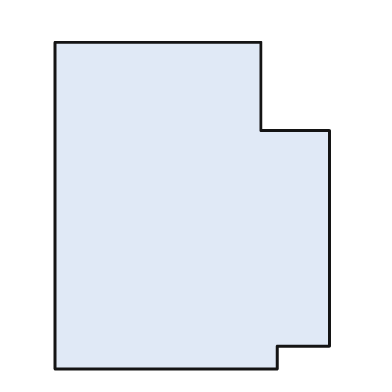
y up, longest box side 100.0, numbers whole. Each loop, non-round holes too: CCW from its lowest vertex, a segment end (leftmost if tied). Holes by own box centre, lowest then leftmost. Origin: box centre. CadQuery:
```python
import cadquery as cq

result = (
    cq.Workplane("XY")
    .moveTo(-42.0, -50.0)
    .lineTo(26.0, -50.0)
    .lineTo(26.0, -43.0)
    .lineTo(42.0, -43.0)
    .lineTo(42.0, 23.0)
    .lineTo(21.0, 23.0)
    .lineTo(21.0, 50.0)
    .lineTo(-42.0, 50.0)
    .close()
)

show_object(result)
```